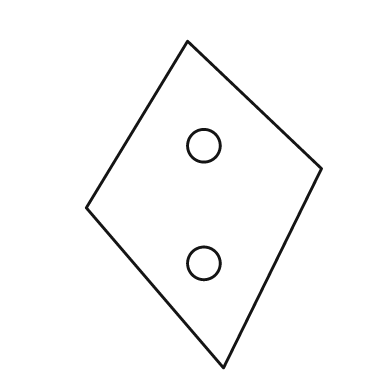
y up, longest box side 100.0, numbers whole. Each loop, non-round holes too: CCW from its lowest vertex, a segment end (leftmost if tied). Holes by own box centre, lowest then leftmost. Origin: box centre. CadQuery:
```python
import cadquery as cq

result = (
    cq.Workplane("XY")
    .moveTo(6.0, -50.0)
    .lineTo(36.0, 11.0)
    .lineTo(-5.0, 50.0)
    .lineTo(-36.0, -1.0)
    .close()
    .moveTo(0.0, -18.0)
    .circle(5.0)
    .moveTo(0.0, 18.0)
    .circle(5.0)
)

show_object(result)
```